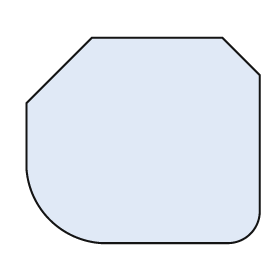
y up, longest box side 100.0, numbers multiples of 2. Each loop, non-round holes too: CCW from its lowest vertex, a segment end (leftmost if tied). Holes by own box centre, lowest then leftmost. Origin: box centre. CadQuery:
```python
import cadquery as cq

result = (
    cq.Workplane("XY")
    .moveTo(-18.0, -44.0)
    .lineTo(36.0, -44.0)
    .threePointArc((46.0, -40.0), (50.0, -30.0))
    .lineTo(50.0, 28.0)
    .lineTo(34.0, 44.0)
    .lineTo(-22.0, 44.0)
    .lineTo(-50.0, 16.0)
    .lineTo(-50.0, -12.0)
    .threePointArc((-40.0, -34.0), (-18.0, -44.0))
    .close()
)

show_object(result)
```